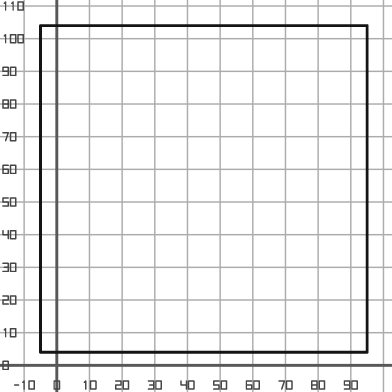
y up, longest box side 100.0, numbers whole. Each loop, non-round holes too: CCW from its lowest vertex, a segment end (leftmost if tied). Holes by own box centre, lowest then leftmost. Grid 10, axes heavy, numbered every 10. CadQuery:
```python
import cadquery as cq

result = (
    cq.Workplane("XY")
    .moveTo(-5.0, 4.0)
    .lineTo(95.0, 4.0)
    .lineTo(95.0, 104.0)
    .lineTo(-5.0, 104.0)
    .close()
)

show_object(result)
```